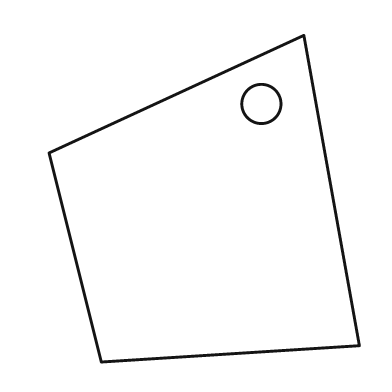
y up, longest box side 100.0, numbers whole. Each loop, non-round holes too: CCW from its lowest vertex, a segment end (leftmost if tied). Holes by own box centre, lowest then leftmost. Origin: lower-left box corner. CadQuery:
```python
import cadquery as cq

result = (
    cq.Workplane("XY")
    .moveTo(16.0, 0.0)
    .lineTo(95.0, 5.0)
    .lineTo(78.0, 100.0)
    .lineTo(0.0, 64.0)
    .close()
    .moveTo(65.0, 79.0)
    .circle(6.0)
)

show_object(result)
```